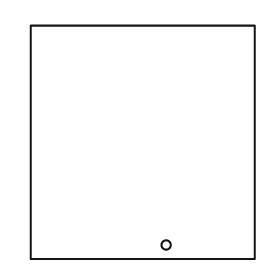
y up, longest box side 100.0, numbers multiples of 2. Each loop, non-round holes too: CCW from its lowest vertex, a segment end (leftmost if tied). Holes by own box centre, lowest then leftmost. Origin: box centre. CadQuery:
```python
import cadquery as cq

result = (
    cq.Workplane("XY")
    .moveTo(-48.0, -50.0)
    .lineTo(48.0, -50.0)
    .lineTo(48.0, 50.0)
    .lineTo(-48.0, 50.0)
    .close()
    .moveTo(10.0, -44.0)
    .circle(2.0)
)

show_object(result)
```